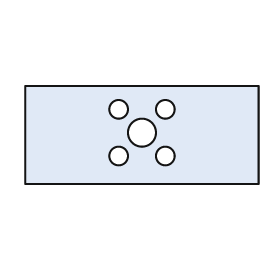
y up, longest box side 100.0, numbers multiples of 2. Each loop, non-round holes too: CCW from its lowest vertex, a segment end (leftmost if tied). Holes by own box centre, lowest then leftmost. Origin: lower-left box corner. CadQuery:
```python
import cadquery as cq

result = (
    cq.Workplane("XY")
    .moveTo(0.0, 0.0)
    .lineTo(100.0, 0.0)
    .lineTo(100.0, 42.0)
    .lineTo(0.0, 42.0)
    .close()
    .moveTo(40.0, 12.0)
    .circle(4.0)
    .moveTo(60.0, 12.0)
    .circle(4.0)
    .moveTo(50.0, 22.0)
    .circle(6.0)
    .moveTo(40.0, 32.0)
    .circle(4.0)
    .moveTo(60.0, 32.0)
    .circle(4.0)
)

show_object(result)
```